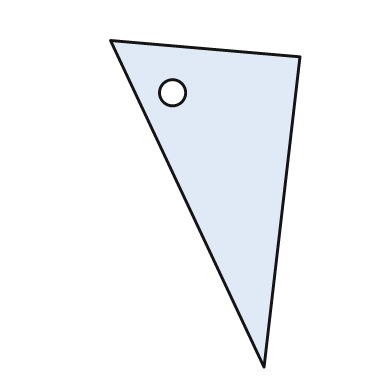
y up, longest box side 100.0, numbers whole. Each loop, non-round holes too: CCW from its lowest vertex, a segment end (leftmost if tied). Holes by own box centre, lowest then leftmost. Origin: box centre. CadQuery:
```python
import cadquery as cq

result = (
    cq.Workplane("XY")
    .moveTo(18.0, -50.0)
    .lineTo(29.0, 45.0)
    .lineTo(-29.0, 50.0)
    .close()
    .moveTo(-10.0, 34.0)
    .circle(4.0)
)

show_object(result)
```